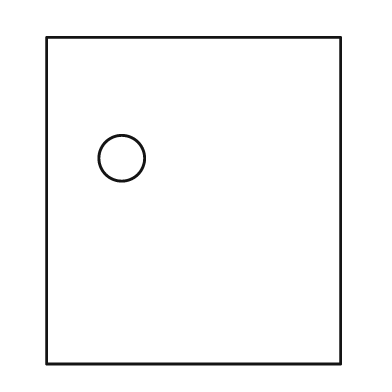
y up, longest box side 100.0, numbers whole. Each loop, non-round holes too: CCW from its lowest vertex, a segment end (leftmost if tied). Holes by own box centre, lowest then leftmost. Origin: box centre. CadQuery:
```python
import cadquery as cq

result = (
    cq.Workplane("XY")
    .moveTo(-45.0, -50.0)
    .lineTo(45.0, -50.0)
    .lineTo(45.0, 50.0)
    .lineTo(-45.0, 50.0)
    .close()
    .moveTo(-22.0, 13.0)
    .circle(7.0)
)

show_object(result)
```